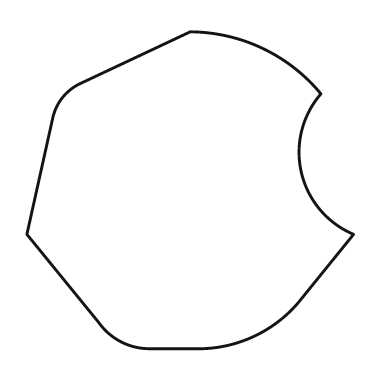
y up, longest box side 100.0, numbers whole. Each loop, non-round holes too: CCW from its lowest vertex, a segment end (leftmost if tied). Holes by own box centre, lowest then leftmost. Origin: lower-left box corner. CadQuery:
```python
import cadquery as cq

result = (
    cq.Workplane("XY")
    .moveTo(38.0, 0.0)
    .lineTo(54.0, 0.0)
    .threePointArc((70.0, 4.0), (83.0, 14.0))
    .lineTo(100.0, 35.0)
    .threePointArc((84.0, 54.0), (90.0, 78.0))
    .threePointArc((72.0, 92.0), (50.0, 97.0))
    .lineTo(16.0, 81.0)
    .threePointArc((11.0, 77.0), (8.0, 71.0))
    .lineTo(0.0, 35.0)
    .lineTo(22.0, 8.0)
    .threePointArc((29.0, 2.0), (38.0, 0.0))
    .close()
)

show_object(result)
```